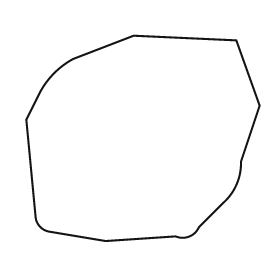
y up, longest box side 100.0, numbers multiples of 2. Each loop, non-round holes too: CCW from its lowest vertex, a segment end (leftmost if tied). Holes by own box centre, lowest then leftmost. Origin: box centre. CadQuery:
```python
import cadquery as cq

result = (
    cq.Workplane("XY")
    .moveTo(-16.0, -44.0)
    .lineTo(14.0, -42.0)
    .threePointArc((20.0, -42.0), (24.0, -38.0))
    .lineTo(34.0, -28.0)
    .threePointArc((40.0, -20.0), (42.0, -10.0))
    .lineTo(50.0, 14.0)
    .lineTo(40.0, 42.0)
    .lineTo(-4.0, 44.0)
    .lineTo(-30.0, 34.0)
    .threePointArc((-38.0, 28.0), (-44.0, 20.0))
    .lineTo(-50.0, 8.0)
    .lineTo(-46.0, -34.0)
    .threePointArc((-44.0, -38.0), (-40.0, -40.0))
    .close()
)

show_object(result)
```